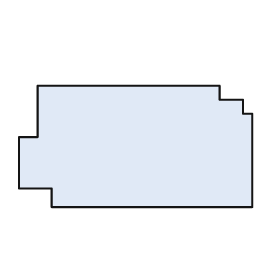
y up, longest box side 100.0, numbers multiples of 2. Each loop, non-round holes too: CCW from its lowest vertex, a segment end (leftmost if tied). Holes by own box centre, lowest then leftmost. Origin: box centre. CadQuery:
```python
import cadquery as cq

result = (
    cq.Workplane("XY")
    .moveTo(-36.0, -26.0)
    .lineTo(50.0, -26.0)
    .lineTo(50.0, 14.0)
    .lineTo(46.0, 14.0)
    .lineTo(46.0, 20.0)
    .lineTo(36.0, 20.0)
    .lineTo(36.0, 26.0)
    .lineTo(-42.0, 26.0)
    .lineTo(-42.0, 4.0)
    .lineTo(-50.0, 4.0)
    .lineTo(-50.0, -18.0)
    .lineTo(-36.0, -18.0)
    .close()
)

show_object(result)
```